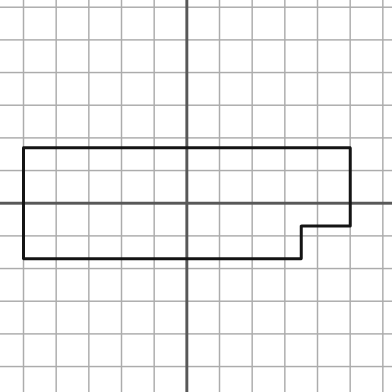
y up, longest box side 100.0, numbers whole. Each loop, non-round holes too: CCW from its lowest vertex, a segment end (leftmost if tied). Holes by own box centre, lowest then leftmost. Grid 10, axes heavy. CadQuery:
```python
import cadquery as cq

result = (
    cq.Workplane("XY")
    .moveTo(-50.0, -17.0)
    .lineTo(35.0, -17.0)
    .lineTo(35.0, -7.0)
    .lineTo(50.0, -7.0)
    .lineTo(50.0, 17.0)
    .lineTo(-50.0, 17.0)
    .close()
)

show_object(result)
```